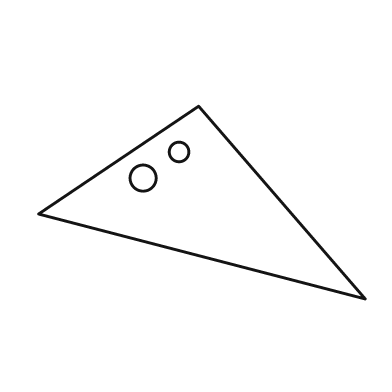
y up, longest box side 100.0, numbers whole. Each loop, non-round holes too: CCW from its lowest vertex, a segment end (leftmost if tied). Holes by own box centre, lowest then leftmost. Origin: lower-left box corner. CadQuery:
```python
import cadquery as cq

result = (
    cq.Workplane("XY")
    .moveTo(100.0, 0.0)
    .lineTo(49.0, 59.0)
    .lineTo(0.0, 26.0)
    .close()
    .moveTo(32.0, 37.0)
    .circle(4.0)
    .moveTo(43.0, 45.0)
    .circle(3.0)
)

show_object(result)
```